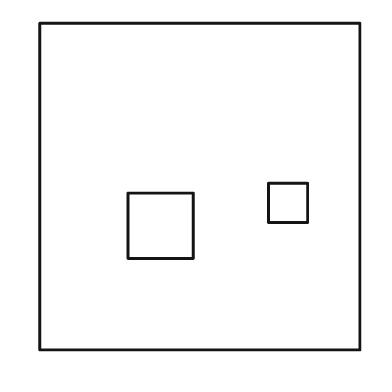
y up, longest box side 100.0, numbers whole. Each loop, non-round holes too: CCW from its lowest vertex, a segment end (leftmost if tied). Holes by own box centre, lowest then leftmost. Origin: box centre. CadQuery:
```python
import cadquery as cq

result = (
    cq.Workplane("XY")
    .moveTo(-49.0, -50.0)
    .lineTo(49.0, -50.0)
    .lineTo(49.0, 50.0)
    .lineTo(-49.0, 50.0)
    .close()
    .moveTo(-22.0, -22.0)
    .lineTo(-2.0, -22.0)
    .lineTo(-2.0, -2.0)
    .lineTo(-22.0, -2.0)
    .close()
    .moveTo(21.0, -11.0)
    .lineTo(33.0, -11.0)
    .lineTo(33.0, 1.0)
    .lineTo(21.0, 1.0)
    .close()
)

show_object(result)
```